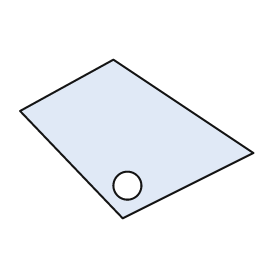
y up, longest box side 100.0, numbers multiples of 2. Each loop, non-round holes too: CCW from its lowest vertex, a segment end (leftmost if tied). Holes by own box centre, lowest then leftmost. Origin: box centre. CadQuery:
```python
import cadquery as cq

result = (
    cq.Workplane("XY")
    .moveTo(-6.0, -34.0)
    .lineTo(50.0, -6.0)
    .lineTo(-10.0, 34.0)
    .lineTo(-50.0, 12.0)
    .close()
    .moveTo(-4.0, -20.0)
    .circle(6.0)
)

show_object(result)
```